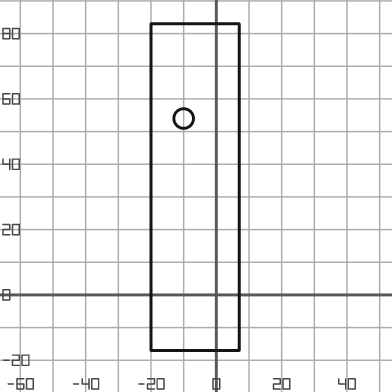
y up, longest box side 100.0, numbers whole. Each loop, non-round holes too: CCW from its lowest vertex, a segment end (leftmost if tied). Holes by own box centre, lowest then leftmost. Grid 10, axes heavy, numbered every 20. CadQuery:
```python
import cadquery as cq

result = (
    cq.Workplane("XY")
    .moveTo(-20.0, -17.0)
    .lineTo(7.0, -17.0)
    .lineTo(7.0, 83.0)
    .lineTo(-20.0, 83.0)
    .close()
    .moveTo(-10.0, 54.0)
    .circle(3.0)
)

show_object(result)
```